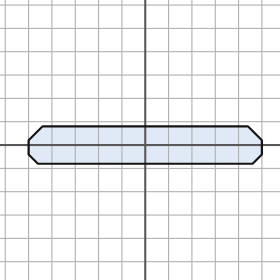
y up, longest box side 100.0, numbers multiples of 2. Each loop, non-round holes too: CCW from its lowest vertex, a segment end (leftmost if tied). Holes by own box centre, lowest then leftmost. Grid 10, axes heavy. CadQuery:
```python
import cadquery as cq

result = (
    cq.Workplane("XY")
    .moveTo(-46.0, -8.0)
    .lineTo(46.0, -8.0)
    .lineTo(50.0, -4.0)
    .lineTo(50.0, 2.0)
    .lineTo(44.0, 8.0)
    .lineTo(-44.0, 8.0)
    .lineTo(-50.0, 2.0)
    .lineTo(-50.0, -4.0)
    .close()
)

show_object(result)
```